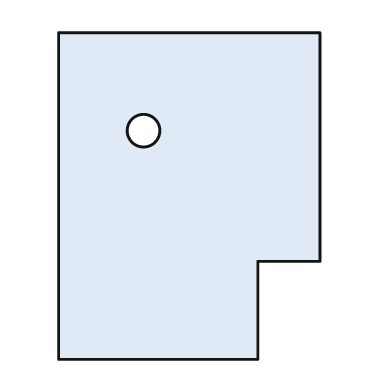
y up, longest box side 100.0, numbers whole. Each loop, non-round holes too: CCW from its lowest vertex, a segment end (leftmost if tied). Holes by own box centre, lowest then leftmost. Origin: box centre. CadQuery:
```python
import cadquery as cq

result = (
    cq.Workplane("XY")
    .moveTo(-40.0, -50.0)
    .lineTo(21.0, -50.0)
    .lineTo(21.0, -20.0)
    .lineTo(40.0, -20.0)
    .lineTo(40.0, 50.0)
    .lineTo(-40.0, 50.0)
    .close()
    .moveTo(-14.0, 20.0)
    .circle(5.0)
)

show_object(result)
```